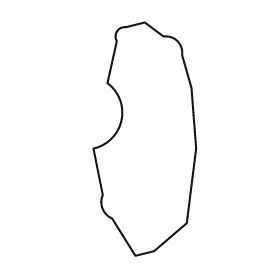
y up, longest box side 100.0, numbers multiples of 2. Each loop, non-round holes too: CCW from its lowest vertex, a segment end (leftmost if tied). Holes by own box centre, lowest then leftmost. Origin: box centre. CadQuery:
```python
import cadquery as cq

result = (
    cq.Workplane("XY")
    .moveTo(-4.0, -50.0)
    .lineTo(4.0, -48.0)
    .lineTo(18.0, -36.0)
    .lineTo(22.0, -4.0)
    .lineTo(20.0, 22.0)
    .lineTo(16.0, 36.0)
    .threePointArc((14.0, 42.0), (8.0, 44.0))
    .lineTo(0.0, 50.0)
    .lineTo(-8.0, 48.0)
    .threePointArc((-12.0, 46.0), (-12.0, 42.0))
    .lineTo(-16.0, 24.0)
    .threePointArc((-10.0, 8.0), (-22.0, -4.0))
    .lineTo(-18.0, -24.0)
    .threePointArc((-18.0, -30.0), (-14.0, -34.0))
    .close()
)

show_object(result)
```